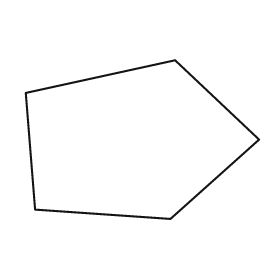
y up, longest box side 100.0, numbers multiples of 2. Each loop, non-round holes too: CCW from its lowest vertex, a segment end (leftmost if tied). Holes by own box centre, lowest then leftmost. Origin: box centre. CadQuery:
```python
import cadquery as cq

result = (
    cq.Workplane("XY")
    .moveTo(12.0, -34.0)
    .lineTo(50.0, 0.0)
    .lineTo(14.0, 34.0)
    .lineTo(-50.0, 20.0)
    .lineTo(-46.0, -30.0)
    .close()
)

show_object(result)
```